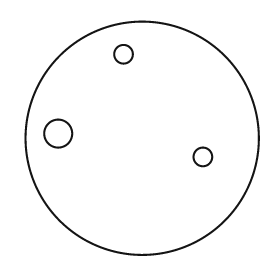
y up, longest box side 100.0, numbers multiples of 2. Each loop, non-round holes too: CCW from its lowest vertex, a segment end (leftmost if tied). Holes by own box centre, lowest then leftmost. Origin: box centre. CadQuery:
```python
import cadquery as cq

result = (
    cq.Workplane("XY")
    .moveTo(0.0, 0.0)
    .circle(50.0)
    .moveTo(26.0, -8.0)
    .circle(4.0)
    .moveTo(-36.0, 2.0)
    .circle(6.0)
    .moveTo(-8.0, 36.0)
    .circle(4.0)
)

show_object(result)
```